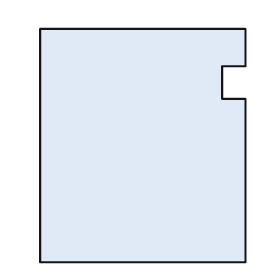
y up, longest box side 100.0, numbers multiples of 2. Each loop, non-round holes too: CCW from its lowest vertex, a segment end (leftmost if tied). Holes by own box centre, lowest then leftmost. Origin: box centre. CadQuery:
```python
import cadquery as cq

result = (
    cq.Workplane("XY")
    .moveTo(-44.0, -50.0)
    .lineTo(44.0, -50.0)
    .lineTo(44.0, 20.0)
    .lineTo(34.0, 20.0)
    .lineTo(34.0, 34.0)
    .lineTo(44.0, 34.0)
    .lineTo(44.0, 50.0)
    .lineTo(-44.0, 50.0)
    .close()
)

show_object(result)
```